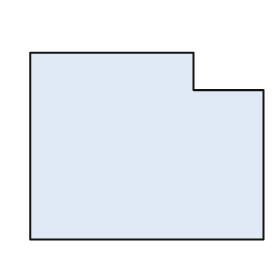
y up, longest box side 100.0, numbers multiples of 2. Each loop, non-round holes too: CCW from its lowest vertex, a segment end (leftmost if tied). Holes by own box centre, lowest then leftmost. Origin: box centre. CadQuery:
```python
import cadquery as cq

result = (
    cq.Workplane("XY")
    .moveTo(-50.0, -40.0)
    .lineTo(50.0, -40.0)
    .lineTo(50.0, 24.0)
    .lineTo(20.0, 24.0)
    .lineTo(20.0, 40.0)
    .lineTo(-50.0, 40.0)
    .close()
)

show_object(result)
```